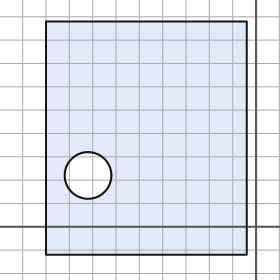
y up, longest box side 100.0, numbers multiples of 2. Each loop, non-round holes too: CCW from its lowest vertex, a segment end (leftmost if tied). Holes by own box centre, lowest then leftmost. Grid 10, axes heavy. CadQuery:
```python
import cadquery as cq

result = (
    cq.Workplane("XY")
    .moveTo(-90.0, -12.0)
    .lineTo(-4.0, -12.0)
    .lineTo(-4.0, 88.0)
    .lineTo(-90.0, 88.0)
    .close()
    .moveTo(-72.0, 22.0)
    .circle(10.0)
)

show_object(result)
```